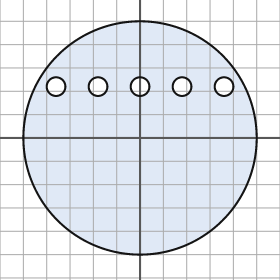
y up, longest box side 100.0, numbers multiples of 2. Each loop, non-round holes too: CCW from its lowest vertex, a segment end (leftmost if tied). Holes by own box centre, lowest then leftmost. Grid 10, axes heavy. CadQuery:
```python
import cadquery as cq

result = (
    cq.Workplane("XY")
    .moveTo(0.0, 0.0)
    .circle(50.0)
    .moveTo(-36.0, 22.0)
    .circle(4.0)
    .moveTo(-18.0, 22.0)
    .circle(4.0)
    .moveTo(0.0, 22.0)
    .circle(4.0)
    .moveTo(18.0, 22.0)
    .circle(4.0)
    .moveTo(36.0, 22.0)
    .circle(4.0)
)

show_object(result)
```